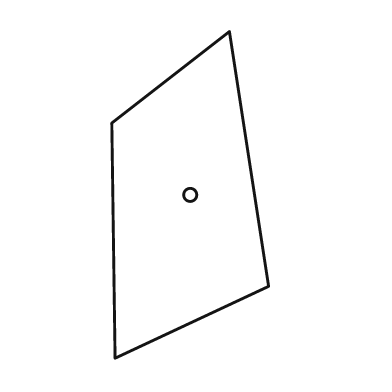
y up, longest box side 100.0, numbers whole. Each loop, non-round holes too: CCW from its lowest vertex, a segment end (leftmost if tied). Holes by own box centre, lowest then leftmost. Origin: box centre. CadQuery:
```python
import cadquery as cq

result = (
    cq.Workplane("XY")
    .moveTo(-23.0, -50.0)
    .lineTo(24.0, -28.0)
    .lineTo(12.0, 50.0)
    .lineTo(-24.0, 22.0)
    .close()
    .moveTo(0.0, 0.0)
    .circle(2.0)
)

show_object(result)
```